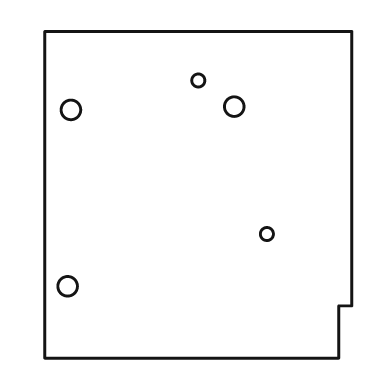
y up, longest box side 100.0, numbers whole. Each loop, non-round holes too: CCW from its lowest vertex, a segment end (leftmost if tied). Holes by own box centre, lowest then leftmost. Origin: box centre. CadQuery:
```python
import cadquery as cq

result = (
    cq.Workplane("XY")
    .moveTo(-47.0, -50.0)
    .lineTo(43.0, -50.0)
    .lineTo(43.0, -34.0)
    .lineTo(47.0, -34.0)
    .lineTo(47.0, 50.0)
    .lineTo(-47.0, 50.0)
    .close()
    .moveTo(-40.0, -28.0)
    .circle(3.0)
    .moveTo(21.0, -12.0)
    .circle(2.0)
    .moveTo(-39.0, 26.0)
    .circle(3.0)
    .moveTo(11.0, 27.0)
    .circle(3.0)
    .moveTo(0.0, 35.0)
    .circle(2.0)
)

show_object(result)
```